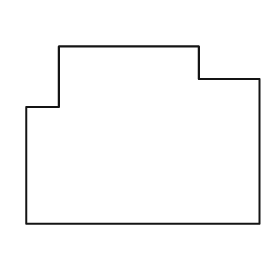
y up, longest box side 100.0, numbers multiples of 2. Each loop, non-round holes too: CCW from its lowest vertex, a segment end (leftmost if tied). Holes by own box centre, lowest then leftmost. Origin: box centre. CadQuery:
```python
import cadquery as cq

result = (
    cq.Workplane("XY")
    .moveTo(-50.0, -38.0)
    .lineTo(50.0, -38.0)
    .lineTo(50.0, 24.0)
    .lineTo(24.0, 24.0)
    .lineTo(24.0, 38.0)
    .lineTo(-36.0, 38.0)
    .lineTo(-36.0, 12.0)
    .lineTo(-50.0, 12.0)
    .close()
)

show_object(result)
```